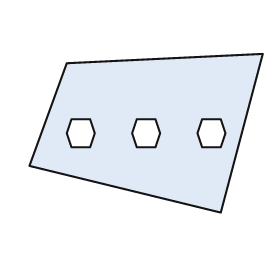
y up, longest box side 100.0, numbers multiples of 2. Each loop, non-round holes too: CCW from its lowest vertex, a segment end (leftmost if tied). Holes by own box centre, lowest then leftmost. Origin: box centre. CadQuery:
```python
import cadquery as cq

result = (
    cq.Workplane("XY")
    .moveTo(32.0, -34.0)
    .lineTo(50.0, 34.0)
    .lineTo(-34.0, 30.0)
    .lineTo(-50.0, -14.0)
    .close()
    .moveTo(-32.0, -6.0)
    .lineTo(-24.0, -6.0)
    .lineTo(-22.0, 0.0)
    .lineTo(-24.0, 6.0)
    .lineTo(-32.0, 6.0)
    .lineTo(-34.0, 0.0)
    .close()
    .moveTo(-4.0, -6.0)
    .lineTo(4.0, -6.0)
    .lineTo(6.0, 0.0)
    .lineTo(4.0, 6.0)
    .lineTo(-4.0, 6.0)
    .lineTo(-6.0, 0.0)
    .close()
    .moveTo(24.0, -6.0)
    .lineTo(32.0, -6.0)
    .lineTo(34.0, 0.0)
    .lineTo(32.0, 6.0)
    .lineTo(24.0, 6.0)
    .lineTo(22.0, 0.0)
    .close()
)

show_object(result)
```